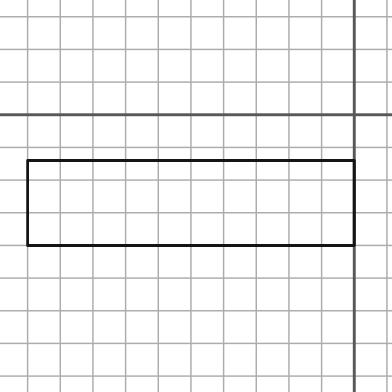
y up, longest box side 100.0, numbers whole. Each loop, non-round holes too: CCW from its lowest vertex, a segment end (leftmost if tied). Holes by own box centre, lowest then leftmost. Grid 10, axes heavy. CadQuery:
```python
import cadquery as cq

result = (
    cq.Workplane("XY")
    .moveTo(-100.0, -40.0)
    .lineTo(0.0, -40.0)
    .lineTo(0.0, -14.0)
    .lineTo(-100.0, -14.0)
    .close()
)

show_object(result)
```